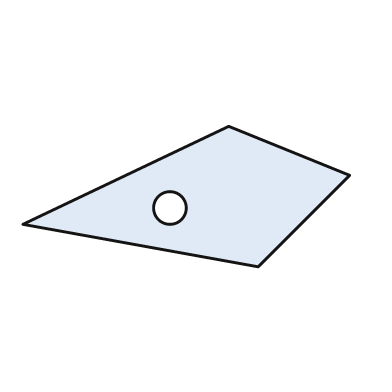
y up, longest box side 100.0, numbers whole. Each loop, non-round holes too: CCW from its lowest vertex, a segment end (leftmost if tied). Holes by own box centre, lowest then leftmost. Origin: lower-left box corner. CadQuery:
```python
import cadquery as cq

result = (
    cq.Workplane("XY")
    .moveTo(72.0, 0.0)
    .lineTo(100.0, 28.0)
    .lineTo(63.0, 43.0)
    .lineTo(0.0, 13.0)
    .close()
    .moveTo(45.0, 18.0)
    .circle(5.0)
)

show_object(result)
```